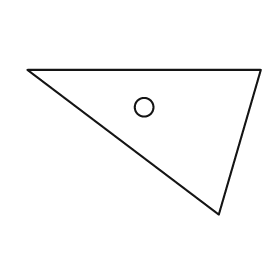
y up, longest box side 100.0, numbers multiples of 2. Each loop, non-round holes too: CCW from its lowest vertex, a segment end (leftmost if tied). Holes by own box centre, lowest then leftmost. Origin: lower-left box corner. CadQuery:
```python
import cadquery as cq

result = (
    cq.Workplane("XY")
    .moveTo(82.0, 0.0)
    .lineTo(100.0, 62.0)
    .lineTo(0.0, 62.0)
    .close()
    .moveTo(50.0, 46.0)
    .circle(4.0)
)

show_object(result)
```